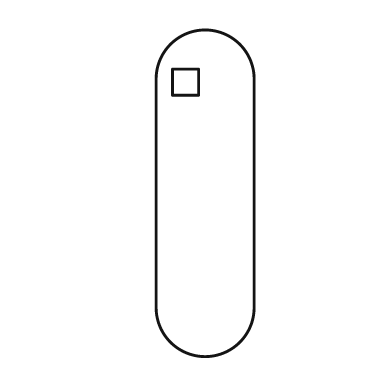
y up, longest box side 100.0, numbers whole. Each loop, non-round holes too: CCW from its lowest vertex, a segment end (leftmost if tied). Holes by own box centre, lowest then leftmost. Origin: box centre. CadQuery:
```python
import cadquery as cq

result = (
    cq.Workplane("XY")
    .moveTo(-15.0, -35.0)
    .threePointArc((0.0, -50.0), (15.0, -35.0))
    .lineTo(15.0, 35.0)
    .threePointArc((0.0, 50.0), (-15.0, 35.0))
    .close()
    .moveTo(-10.0, 30.0)
    .lineTo(-2.0, 30.0)
    .lineTo(-2.0, 38.0)
    .lineTo(-10.0, 38.0)
    .close()
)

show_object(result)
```